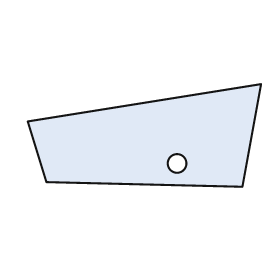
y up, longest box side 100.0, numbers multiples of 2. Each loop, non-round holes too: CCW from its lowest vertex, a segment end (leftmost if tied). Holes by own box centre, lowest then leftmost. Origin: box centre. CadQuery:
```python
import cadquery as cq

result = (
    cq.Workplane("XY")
    .moveTo(42.0, -22.0)
    .lineTo(50.0, 22.0)
    .lineTo(-50.0, 6.0)
    .lineTo(-42.0, -20.0)
    .close()
    .moveTo(14.0, -12.0)
    .circle(4.0)
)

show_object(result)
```